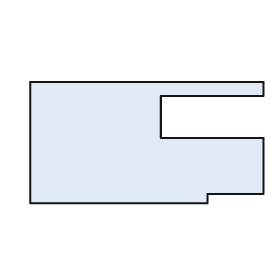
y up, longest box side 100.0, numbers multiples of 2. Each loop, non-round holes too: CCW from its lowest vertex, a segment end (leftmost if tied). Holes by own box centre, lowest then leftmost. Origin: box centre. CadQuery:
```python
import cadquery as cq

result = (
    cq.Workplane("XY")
    .moveTo(-50.0, -26.0)
    .lineTo(26.0, -26.0)
    .lineTo(26.0, -22.0)
    .lineTo(50.0, -22.0)
    .lineTo(50.0, 2.0)
    .lineTo(6.0, 2.0)
    .lineTo(6.0, 20.0)
    .lineTo(50.0, 20.0)
    .lineTo(50.0, 26.0)
    .lineTo(-50.0, 26.0)
    .close()
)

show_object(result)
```